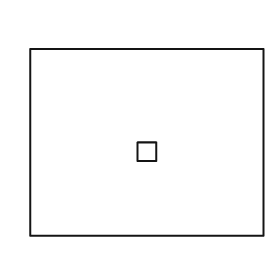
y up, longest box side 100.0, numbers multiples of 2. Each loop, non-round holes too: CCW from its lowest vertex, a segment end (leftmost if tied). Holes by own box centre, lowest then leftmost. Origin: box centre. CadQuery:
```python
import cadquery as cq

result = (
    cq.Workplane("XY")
    .moveTo(-50.0, -40.0)
    .lineTo(50.0, -40.0)
    .lineTo(50.0, 40.0)
    .lineTo(-50.0, 40.0)
    .close()
    .moveTo(-4.0, -8.0)
    .lineTo(4.0, -8.0)
    .lineTo(4.0, 0.0)
    .lineTo(-4.0, 0.0)
    .close()
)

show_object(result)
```